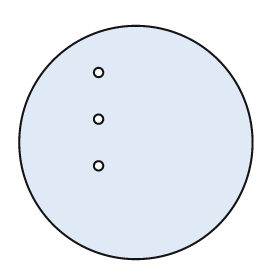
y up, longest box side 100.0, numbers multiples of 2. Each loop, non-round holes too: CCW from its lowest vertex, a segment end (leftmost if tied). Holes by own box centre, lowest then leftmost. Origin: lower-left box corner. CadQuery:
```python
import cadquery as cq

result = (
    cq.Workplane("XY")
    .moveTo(50.0, 50.0)
    .circle(50.0)
    .moveTo(34.0, 40.0)
    .circle(2.0)
    .moveTo(34.0, 60.0)
    .circle(2.0)
    .moveTo(34.0, 80.0)
    .circle(2.0)
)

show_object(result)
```